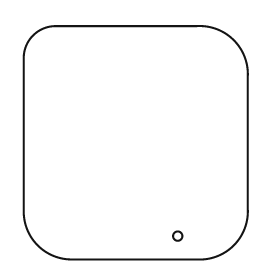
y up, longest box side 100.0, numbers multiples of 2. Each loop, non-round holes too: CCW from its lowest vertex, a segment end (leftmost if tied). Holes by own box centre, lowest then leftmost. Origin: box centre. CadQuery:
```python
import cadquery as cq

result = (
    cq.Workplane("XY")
    .moveTo(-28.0, -50.0)
    .lineTo(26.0, -50.0)
    .threePointArc((42.0, -44.0), (48.0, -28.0))
    .lineTo(48.0, 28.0)
    .threePointArc((42.0, 44.0), (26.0, 50.0))
    .lineTo(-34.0, 50.0)
    .threePointArc((-44.0, 46.0), (-48.0, 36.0))
    .lineTo(-48.0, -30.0)
    .threePointArc((-42.0, -44.0), (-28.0, -50.0))
    .close()
    .moveTo(18.0, -40.0)
    .circle(2.0)
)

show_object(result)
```